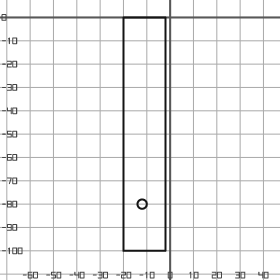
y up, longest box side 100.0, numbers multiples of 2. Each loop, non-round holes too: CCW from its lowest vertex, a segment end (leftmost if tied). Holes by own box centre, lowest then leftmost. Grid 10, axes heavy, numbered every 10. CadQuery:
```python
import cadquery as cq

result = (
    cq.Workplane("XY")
    .moveTo(-20.0, -100.0)
    .lineTo(-2.0, -100.0)
    .lineTo(-2.0, 0.0)
    .lineTo(-20.0, 0.0)
    .close()
    .moveTo(-12.0, -80.0)
    .circle(2.0)
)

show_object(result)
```